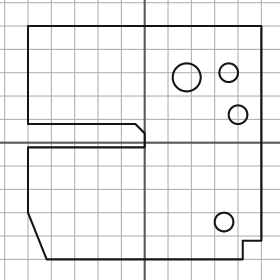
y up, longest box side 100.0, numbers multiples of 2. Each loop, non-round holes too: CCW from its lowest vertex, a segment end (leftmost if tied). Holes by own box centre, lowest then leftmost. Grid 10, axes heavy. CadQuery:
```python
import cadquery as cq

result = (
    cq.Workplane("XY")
    .moveTo(-42.0, -50.0)
    .lineTo(42.0, -50.0)
    .lineTo(42.0, -42.0)
    .lineTo(50.0, -42.0)
    .lineTo(50.0, 50.0)
    .lineTo(-50.0, 50.0)
    .lineTo(-50.0, 8.0)
    .lineTo(-4.0, 8.0)
    .lineTo(0.0, 4.0)
    .lineTo(0.0, -2.0)
    .lineTo(-50.0, -2.0)
    .lineTo(-50.0, -30.0)
    .close()
    .moveTo(34.0, -34.0)
    .circle(4.0)
    .moveTo(40.0, 12.0)
    .circle(4.0)
    .moveTo(18.0, 28.0)
    .circle(6.0)
    .moveTo(36.0, 30.0)
    .circle(4.0)
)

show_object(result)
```